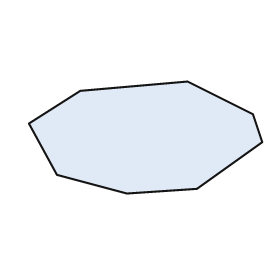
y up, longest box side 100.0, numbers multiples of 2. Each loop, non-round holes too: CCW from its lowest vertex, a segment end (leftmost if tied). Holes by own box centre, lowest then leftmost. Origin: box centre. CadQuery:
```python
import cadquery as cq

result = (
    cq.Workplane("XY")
    .moveTo(-8.0, -24.0)
    .lineTo(22.0, -22.0)
    .lineTo(50.0, -2.0)
    .lineTo(46.0, 10.0)
    .lineTo(18.0, 24.0)
    .lineTo(-28.0, 20.0)
    .lineTo(-50.0, 6.0)
    .lineTo(-38.0, -16.0)
    .close()
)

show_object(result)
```